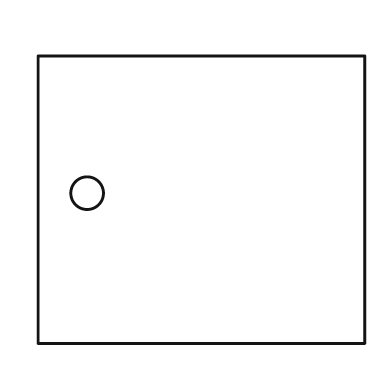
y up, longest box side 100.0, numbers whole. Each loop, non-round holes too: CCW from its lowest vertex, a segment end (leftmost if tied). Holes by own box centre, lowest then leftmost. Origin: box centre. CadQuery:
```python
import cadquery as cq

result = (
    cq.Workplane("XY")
    .moveTo(-50.0, -44.0)
    .lineTo(50.0, -44.0)
    .lineTo(50.0, 44.0)
    .lineTo(-50.0, 44.0)
    .close()
    .moveTo(-35.0, 2.0)
    .circle(5.0)
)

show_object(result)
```